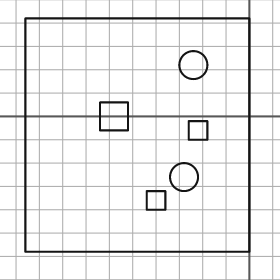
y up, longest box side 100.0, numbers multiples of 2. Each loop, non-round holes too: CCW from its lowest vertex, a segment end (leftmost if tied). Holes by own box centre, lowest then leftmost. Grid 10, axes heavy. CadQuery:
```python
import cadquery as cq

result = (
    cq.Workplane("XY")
    .moveTo(-96.0, -58.0)
    .lineTo(0.0, -58.0)
    .lineTo(0.0, 42.0)
    .lineTo(-96.0, 42.0)
    .close()
    .moveTo(-44.0, -40.0)
    .lineTo(-36.0, -40.0)
    .lineTo(-36.0, -32.0)
    .lineTo(-44.0, -32.0)
    .close()
    .moveTo(-28.0, -26.0)
    .circle(6.0)
    .moveTo(-26.0, -10.0)
    .lineTo(-18.0, -10.0)
    .lineTo(-18.0, -2.0)
    .lineTo(-26.0, -2.0)
    .close()
    .moveTo(-64.0, -6.0)
    .lineTo(-52.0, -6.0)
    .lineTo(-52.0, 6.0)
    .lineTo(-64.0, 6.0)
    .close()
    .moveTo(-24.0, 22.0)
    .circle(6.0)
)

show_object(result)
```